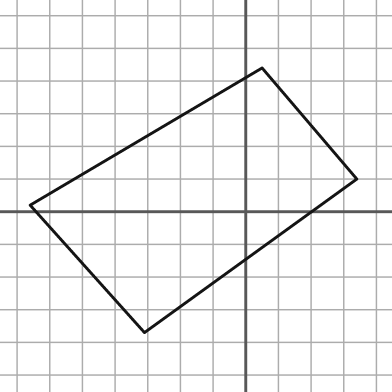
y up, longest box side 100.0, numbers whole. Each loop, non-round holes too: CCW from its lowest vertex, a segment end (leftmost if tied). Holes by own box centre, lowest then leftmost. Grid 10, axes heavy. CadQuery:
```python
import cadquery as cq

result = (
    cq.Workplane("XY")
    .moveTo(-31.0, -37.0)
    .lineTo(34.0, 10.0)
    .lineTo(5.0, 44.0)
    .lineTo(-66.0, 2.0)
    .close()
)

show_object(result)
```